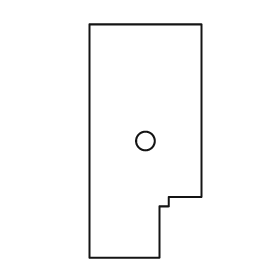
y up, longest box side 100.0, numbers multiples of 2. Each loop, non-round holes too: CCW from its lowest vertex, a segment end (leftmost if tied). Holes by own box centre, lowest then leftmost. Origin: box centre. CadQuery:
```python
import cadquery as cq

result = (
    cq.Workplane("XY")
    .moveTo(-24.0, -50.0)
    .lineTo(6.0, -50.0)
    .lineTo(6.0, -28.0)
    .lineTo(10.0, -28.0)
    .lineTo(10.0, -24.0)
    .lineTo(24.0, -24.0)
    .lineTo(24.0, 50.0)
    .lineTo(-24.0, 50.0)
    .close()
    .moveTo(0.0, 0.0)
    .circle(4.0)
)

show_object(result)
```